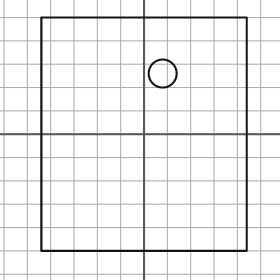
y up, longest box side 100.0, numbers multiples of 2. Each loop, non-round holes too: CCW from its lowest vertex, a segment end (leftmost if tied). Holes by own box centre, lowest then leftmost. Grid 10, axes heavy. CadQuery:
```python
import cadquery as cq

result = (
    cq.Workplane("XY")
    .moveTo(-44.0, -50.0)
    .lineTo(44.0, -50.0)
    .lineTo(44.0, 50.0)
    .lineTo(-44.0, 50.0)
    .close()
    .moveTo(8.0, 26.0)
    .circle(6.0)
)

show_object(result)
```